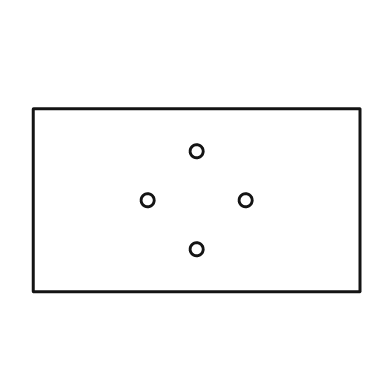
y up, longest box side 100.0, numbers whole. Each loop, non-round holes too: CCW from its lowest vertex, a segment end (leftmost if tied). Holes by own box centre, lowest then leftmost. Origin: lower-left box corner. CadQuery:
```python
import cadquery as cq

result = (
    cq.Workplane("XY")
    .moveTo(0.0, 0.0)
    .lineTo(100.0, 0.0)
    .lineTo(100.0, 56.0)
    .lineTo(0.0, 56.0)
    .close()
    .moveTo(50.0, 13.0)
    .circle(2.0)
    .moveTo(35.0, 28.0)
    .circle(2.0)
    .moveTo(65.0, 28.0)
    .circle(2.0)
    .moveTo(50.0, 43.0)
    .circle(2.0)
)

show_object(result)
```